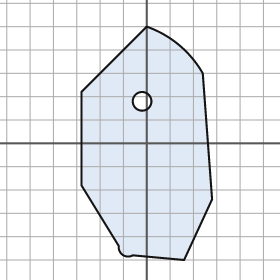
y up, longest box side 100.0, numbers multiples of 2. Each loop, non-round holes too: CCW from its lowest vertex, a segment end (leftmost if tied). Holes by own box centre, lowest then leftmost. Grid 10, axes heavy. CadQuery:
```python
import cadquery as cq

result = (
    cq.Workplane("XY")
    .moveTo(16.0, -50.0)
    .lineTo(28.0, -24.0)
    .lineTo(24.0, 30.0)
    .threePointArc((14.0, 42.0), (0.0, 50.0))
    .lineTo(-28.0, 22.0)
    .lineTo(-28.0, -18.0)
    .lineTo(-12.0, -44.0)
    .threePointArc((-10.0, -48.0), (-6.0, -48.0))
    .close()
    .moveTo(-2.0, 18.0)
    .circle(4.0)
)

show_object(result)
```